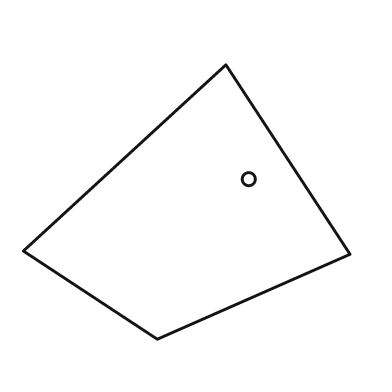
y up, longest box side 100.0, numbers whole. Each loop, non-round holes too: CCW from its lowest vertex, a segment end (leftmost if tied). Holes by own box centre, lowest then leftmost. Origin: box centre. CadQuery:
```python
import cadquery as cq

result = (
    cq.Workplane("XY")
    .moveTo(-9.0, -42.0)
    .lineTo(50.0, -16.0)
    .lineTo(12.0, 42.0)
    .lineTo(-50.0, -15.0)
    .close()
    .moveTo(19.0, 7.0)
    .circle(2.0)
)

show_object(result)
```